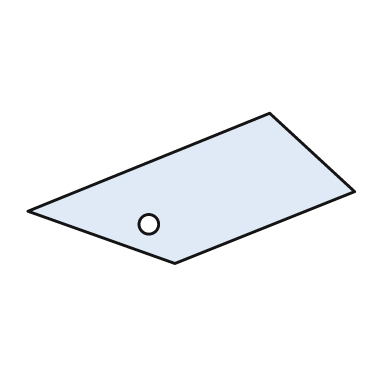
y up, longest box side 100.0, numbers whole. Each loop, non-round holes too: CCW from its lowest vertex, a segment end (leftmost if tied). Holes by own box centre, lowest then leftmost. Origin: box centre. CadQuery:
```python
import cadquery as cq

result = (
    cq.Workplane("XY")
    .moveTo(-5.0, -23.0)
    .lineTo(50.0, -1.0)
    .lineTo(24.0, 23.0)
    .lineTo(-50.0, -7.0)
    .close()
    .moveTo(-13.0, -11.0)
    .circle(3.0)
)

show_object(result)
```